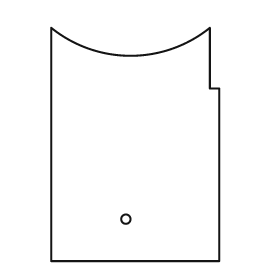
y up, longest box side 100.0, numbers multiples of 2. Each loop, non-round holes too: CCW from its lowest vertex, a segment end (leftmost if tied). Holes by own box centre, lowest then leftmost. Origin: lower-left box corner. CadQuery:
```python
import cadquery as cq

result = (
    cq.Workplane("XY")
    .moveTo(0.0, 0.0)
    .lineTo(72.0, 0.0)
    .lineTo(72.0, 74.0)
    .lineTo(68.0, 74.0)
    .lineTo(68.0, 100.0)
    .threePointArc((34.0, 88.0), (0.0, 100.0))
    .close()
    .moveTo(32.0, 18.0)
    .circle(2.0)
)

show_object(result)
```